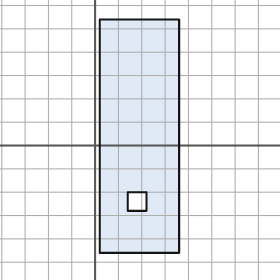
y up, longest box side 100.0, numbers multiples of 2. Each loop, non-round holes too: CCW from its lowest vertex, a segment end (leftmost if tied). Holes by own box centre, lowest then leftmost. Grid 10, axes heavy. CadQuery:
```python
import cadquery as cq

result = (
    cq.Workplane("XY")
    .moveTo(2.0, -46.0)
    .lineTo(36.0, -46.0)
    .lineTo(36.0, 54.0)
    .lineTo(2.0, 54.0)
    .close()
    .moveTo(14.0, -28.0)
    .lineTo(22.0, -28.0)
    .lineTo(22.0, -20.0)
    .lineTo(14.0, -20.0)
    .close()
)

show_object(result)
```